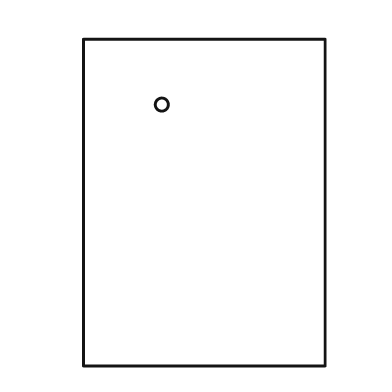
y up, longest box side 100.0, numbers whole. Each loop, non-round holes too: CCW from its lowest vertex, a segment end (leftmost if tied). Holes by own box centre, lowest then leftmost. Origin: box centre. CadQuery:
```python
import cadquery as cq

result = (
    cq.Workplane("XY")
    .moveTo(-37.0, -50.0)
    .lineTo(37.0, -50.0)
    .lineTo(37.0, 50.0)
    .lineTo(-37.0, 50.0)
    .close()
    .moveTo(-13.0, 30.0)
    .circle(2.0)
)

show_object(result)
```